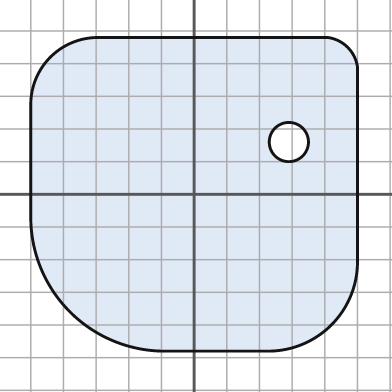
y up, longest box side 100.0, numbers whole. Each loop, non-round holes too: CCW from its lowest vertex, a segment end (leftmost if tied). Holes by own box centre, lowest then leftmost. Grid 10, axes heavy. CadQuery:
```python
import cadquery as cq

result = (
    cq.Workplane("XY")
    .moveTo(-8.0, -48.0)
    .lineTo(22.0, -48.0)
    .threePointArc((42.0, -40.0), (50.0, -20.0))
    .lineTo(50.0, 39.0)
    .threePointArc((47.0, 45.0), (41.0, 48.0))
    .lineTo(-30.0, 48.0)
    .threePointArc((-44.0, 42.0), (-50.0, 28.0))
    .lineTo(-50.0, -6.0)
    .threePointArc((-38.0, -36.0), (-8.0, -48.0))
    .close()
    .moveTo(29.0, 16.0)
    .circle(6.0)
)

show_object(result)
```